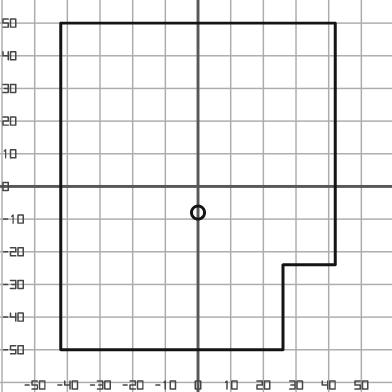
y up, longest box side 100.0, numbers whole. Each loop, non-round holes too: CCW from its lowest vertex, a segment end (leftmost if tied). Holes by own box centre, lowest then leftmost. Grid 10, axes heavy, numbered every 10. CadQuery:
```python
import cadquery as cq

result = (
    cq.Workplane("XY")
    .moveTo(-42.0, -50.0)
    .lineTo(26.0, -50.0)
    .lineTo(26.0, -24.0)
    .lineTo(42.0, -24.0)
    .lineTo(42.0, 50.0)
    .lineTo(-42.0, 50.0)
    .close()
    .moveTo(0.0, -8.0)
    .circle(2.0)
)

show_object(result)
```